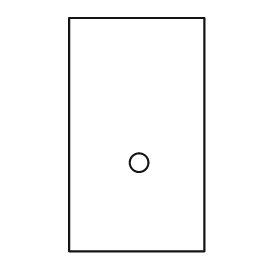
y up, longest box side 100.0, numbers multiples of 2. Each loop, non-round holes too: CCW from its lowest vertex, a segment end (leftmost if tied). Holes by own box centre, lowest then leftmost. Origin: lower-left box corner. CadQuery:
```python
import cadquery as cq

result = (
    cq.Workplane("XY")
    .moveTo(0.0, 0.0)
    .lineTo(58.0, 0.0)
    .lineTo(58.0, 100.0)
    .lineTo(0.0, 100.0)
    .close()
    .moveTo(30.0, 38.0)
    .circle(4.0)
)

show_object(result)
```